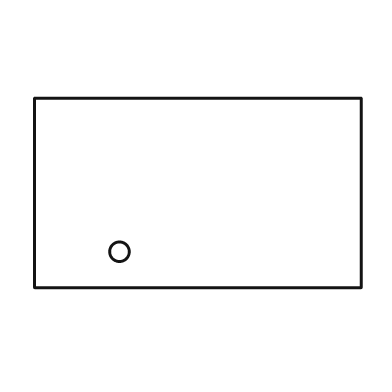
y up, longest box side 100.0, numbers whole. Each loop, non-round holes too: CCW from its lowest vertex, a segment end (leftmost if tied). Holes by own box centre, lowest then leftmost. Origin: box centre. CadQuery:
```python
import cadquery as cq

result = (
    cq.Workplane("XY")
    .moveTo(-50.0, -29.0)
    .lineTo(50.0, -29.0)
    .lineTo(50.0, 29.0)
    .lineTo(-50.0, 29.0)
    .close()
    .moveTo(-24.0, -18.0)
    .circle(3.0)
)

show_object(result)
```